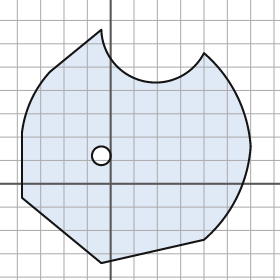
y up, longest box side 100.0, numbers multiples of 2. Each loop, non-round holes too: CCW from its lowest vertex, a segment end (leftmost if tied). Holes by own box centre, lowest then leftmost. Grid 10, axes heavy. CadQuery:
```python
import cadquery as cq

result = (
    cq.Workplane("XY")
    .moveTo(-4.0, -34.0)
    .lineTo(40.0, -24.0)
    .threePointArc((54.0, -6.0), (60.0, 16.0))
    .threePointArc((54.0, 38.0), (40.0, 56.0))
    .threePointArc((14.0, 44.0), (-4.0, 66.0))
    .lineTo(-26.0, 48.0)
    .threePointArc((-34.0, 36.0), (-38.0, 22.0))
    .lineTo(-38.0, -6.0)
    .close()
    .moveTo(-4.0, 12.0)
    .circle(4.0)
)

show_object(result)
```